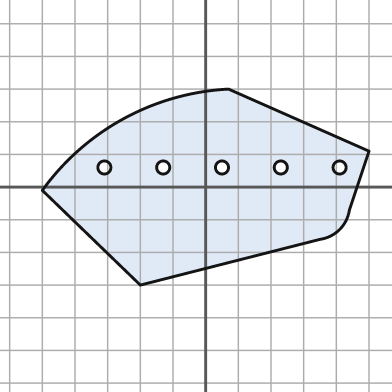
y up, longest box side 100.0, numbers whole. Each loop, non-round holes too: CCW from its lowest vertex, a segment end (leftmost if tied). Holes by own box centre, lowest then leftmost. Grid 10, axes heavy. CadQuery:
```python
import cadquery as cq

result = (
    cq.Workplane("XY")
    .moveTo(-20.0, -30.0)
    .lineTo(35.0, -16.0)
    .threePointArc((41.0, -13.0), (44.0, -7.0))
    .lineTo(50.0, 11.0)
    .lineTo(7.0, 30.0)
    .threePointArc((-25.0, 21.0), (-50.0, -1.0))
    .close()
    .moveTo(-31.0, 6.0)
    .circle(2.0)
    .moveTo(-13.0, 6.0)
    .circle(2.0)
    .moveTo(5.0, 6.0)
    .circle(2.0)
    .moveTo(23.0, 6.0)
    .circle(2.0)
    .moveTo(41.0, 6.0)
    .circle(2.0)
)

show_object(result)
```